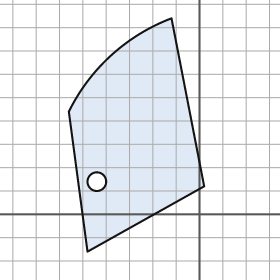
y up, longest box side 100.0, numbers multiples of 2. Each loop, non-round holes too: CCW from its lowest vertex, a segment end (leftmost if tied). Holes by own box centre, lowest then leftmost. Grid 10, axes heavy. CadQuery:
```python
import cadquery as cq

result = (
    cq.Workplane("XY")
    .moveTo(-48.0, -16.0)
    .lineTo(2.0, 12.0)
    .lineTo(-12.0, 84.0)
    .threePointArc((-38.0, 68.0), (-56.0, 44.0))
    .close()
    .moveTo(-44.0, 14.0)
    .circle(4.0)
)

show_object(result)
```